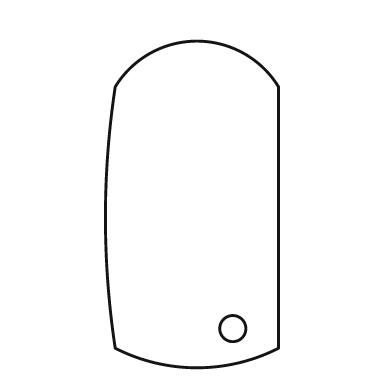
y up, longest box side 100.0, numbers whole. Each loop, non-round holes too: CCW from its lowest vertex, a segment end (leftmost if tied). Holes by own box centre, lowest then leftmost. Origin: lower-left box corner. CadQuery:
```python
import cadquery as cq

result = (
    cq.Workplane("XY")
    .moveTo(3.0, 6.0)
    .threePointArc((28.0, 0.0), (53.0, 6.0))
    .lineTo(53.0, 86.0)
    .threePointArc((28.0, 100.0), (3.0, 86.0))
    .threePointArc((0.0, 46.0), (3.0, 6.0))
    .close()
    .moveTo(39.0, 12.0)
    .circle(4.0)
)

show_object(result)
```